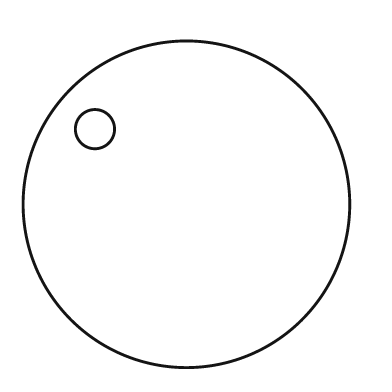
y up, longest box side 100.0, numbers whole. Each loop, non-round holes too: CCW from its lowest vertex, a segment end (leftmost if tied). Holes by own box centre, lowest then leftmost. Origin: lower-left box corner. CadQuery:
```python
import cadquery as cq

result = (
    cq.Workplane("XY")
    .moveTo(50.0, 50.0)
    .circle(50.0)
    .moveTo(22.0, 73.0)
    .circle(6.0)
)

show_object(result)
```